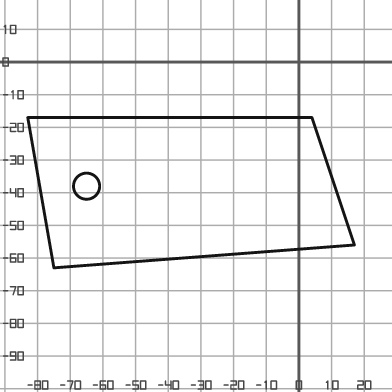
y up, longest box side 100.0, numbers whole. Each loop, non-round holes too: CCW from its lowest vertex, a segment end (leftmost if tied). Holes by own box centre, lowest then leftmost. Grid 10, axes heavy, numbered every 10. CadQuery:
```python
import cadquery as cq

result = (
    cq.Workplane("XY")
    .moveTo(-75.0, -63.0)
    .lineTo(17.0, -56.0)
    .lineTo(4.0, -17.0)
    .lineTo(-83.0, -17.0)
    .close()
    .moveTo(-65.0, -38.0)
    .circle(4.0)
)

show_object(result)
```